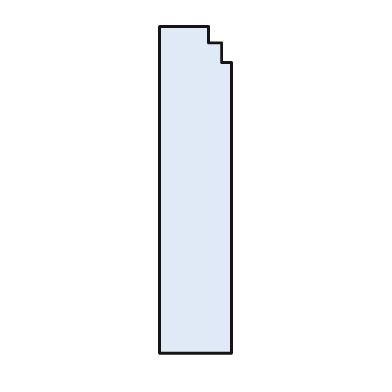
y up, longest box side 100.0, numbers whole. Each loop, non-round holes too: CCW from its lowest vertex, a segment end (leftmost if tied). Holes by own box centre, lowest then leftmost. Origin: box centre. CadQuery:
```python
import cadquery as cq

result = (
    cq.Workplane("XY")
    .moveTo(-11.0, -50.0)
    .lineTo(11.0, -50.0)
    .lineTo(11.0, 39.0)
    .lineTo(8.0, 39.0)
    .lineTo(8.0, 45.0)
    .lineTo(4.0, 45.0)
    .lineTo(4.0, 50.0)
    .lineTo(-11.0, 50.0)
    .close()
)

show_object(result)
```